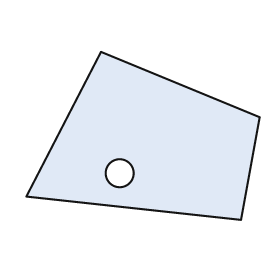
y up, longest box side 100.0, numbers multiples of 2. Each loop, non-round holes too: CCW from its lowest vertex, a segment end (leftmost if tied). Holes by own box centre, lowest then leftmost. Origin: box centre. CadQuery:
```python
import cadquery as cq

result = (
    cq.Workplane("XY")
    .moveTo(42.0, -36.0)
    .lineTo(50.0, 8.0)
    .lineTo(-18.0, 36.0)
    .lineTo(-50.0, -26.0)
    .close()
    .moveTo(-10.0, -16.0)
    .circle(6.0)
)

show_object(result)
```